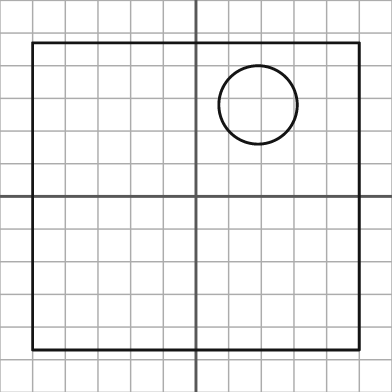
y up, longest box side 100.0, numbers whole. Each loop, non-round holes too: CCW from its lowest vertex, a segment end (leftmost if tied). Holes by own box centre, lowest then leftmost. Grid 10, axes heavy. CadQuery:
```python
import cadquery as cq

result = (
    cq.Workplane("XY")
    .moveTo(-50.0, -47.0)
    .lineTo(50.0, -47.0)
    .lineTo(50.0, 47.0)
    .lineTo(-50.0, 47.0)
    .close()
    .moveTo(19.0, 28.0)
    .circle(12.0)
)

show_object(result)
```